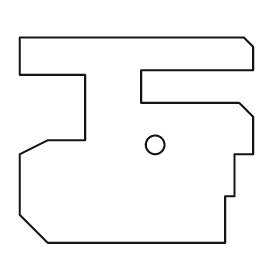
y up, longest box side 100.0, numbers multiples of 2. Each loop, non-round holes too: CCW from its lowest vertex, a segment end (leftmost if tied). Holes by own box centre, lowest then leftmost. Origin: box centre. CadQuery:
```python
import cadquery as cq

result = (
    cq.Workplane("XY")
    .moveTo(-38.0, -44.0)
    .lineTo(38.0, -44.0)
    .lineTo(38.0, -24.0)
    .lineTo(42.0, -24.0)
    .lineTo(42.0, -6.0)
    .lineTo(50.0, -6.0)
    .lineTo(50.0, 10.0)
    .lineTo(44.0, 16.0)
    .lineTo(2.0, 16.0)
    .lineTo(2.0, 30.0)
    .lineTo(50.0, 30.0)
    .lineTo(50.0, 40.0)
    .lineTo(46.0, 44.0)
    .lineTo(-50.0, 44.0)
    .lineTo(-50.0, 28.0)
    .lineTo(-22.0, 28.0)
    .lineTo(-22.0, 0.0)
    .lineTo(-38.0, 0.0)
    .lineTo(-50.0, -6.0)
    .lineTo(-50.0, -32.0)
    .close()
    .moveTo(8.0, -2.0)
    .circle(4.0)
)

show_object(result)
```